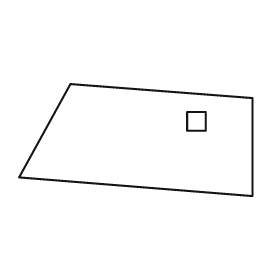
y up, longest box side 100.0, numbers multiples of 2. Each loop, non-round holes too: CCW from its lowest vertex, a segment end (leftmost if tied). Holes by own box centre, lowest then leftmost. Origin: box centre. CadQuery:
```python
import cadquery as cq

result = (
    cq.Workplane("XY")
    .moveTo(50.0, -24.0)
    .lineTo(50.0, 18.0)
    .lineTo(-28.0, 24.0)
    .lineTo(-50.0, -16.0)
    .close()
    .moveTo(22.0, 4.0)
    .lineTo(30.0, 4.0)
    .lineTo(30.0, 12.0)
    .lineTo(22.0, 12.0)
    .close()
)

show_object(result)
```